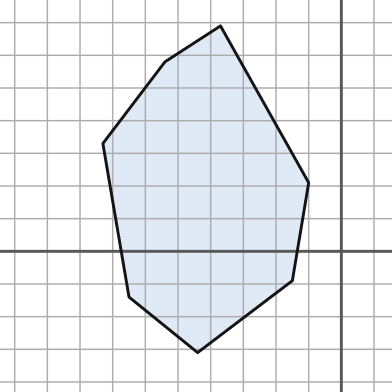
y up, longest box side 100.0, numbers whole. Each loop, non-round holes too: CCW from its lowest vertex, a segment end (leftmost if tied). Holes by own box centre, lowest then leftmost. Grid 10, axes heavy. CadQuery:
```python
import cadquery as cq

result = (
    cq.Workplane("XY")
    .moveTo(-44.0, -31.0)
    .lineTo(-15.0, -9.0)
    .lineTo(-10.0, 21.0)
    .lineTo(-37.0, 69.0)
    .lineTo(-54.0, 58.0)
    .lineTo(-73.0, 33.0)
    .lineTo(-65.0, -14.0)
    .close()
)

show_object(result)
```